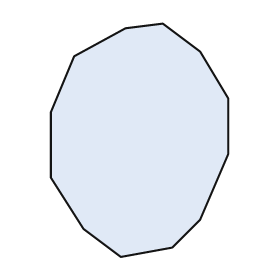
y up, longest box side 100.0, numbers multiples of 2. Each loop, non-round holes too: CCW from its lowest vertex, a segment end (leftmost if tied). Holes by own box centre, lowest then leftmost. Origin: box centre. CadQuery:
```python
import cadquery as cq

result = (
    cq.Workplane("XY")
    .moveTo(-8.0, -50.0)
    .lineTo(14.0, -46.0)
    .lineTo(26.0, -34.0)
    .lineTo(38.0, -6.0)
    .lineTo(38.0, 18.0)
    .lineTo(26.0, 38.0)
    .lineTo(10.0, 50.0)
    .lineTo(-6.0, 48.0)
    .lineTo(-28.0, 36.0)
    .lineTo(-38.0, 12.0)
    .lineTo(-38.0, -16.0)
    .lineTo(-24.0, -38.0)
    .close()
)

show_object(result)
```